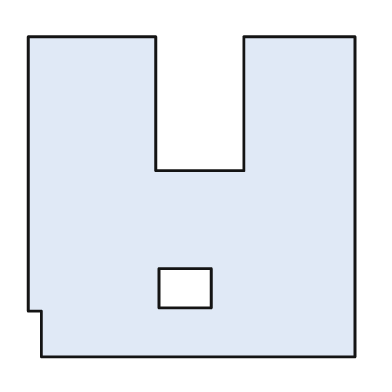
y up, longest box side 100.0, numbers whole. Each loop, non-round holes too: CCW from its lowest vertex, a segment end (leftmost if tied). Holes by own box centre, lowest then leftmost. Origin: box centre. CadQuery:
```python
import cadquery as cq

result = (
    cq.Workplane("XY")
    .moveTo(-46.0, -49.0)
    .lineTo(50.0, -49.0)
    .lineTo(50.0, 49.0)
    .lineTo(16.0, 49.0)
    .lineTo(16.0, 8.0)
    .lineTo(-11.0, 8.0)
    .lineTo(-11.0, 49.0)
    .lineTo(-50.0, 49.0)
    .lineTo(-50.0, -35.0)
    .lineTo(-46.0, -35.0)
    .close()
    .moveTo(-10.0, -34.0)
    .lineTo(6.0, -34.0)
    .lineTo(6.0, -22.0)
    .lineTo(-10.0, -22.0)
    .close()
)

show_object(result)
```